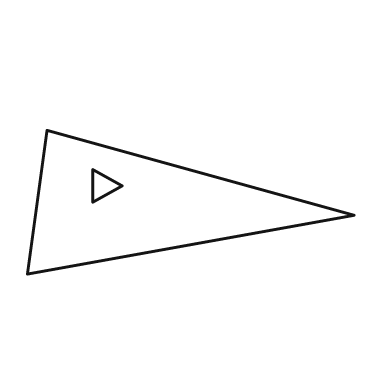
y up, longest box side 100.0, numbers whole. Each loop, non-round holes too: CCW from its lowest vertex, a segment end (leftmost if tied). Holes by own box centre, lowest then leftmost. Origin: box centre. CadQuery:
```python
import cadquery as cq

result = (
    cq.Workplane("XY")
    .moveTo(-50.0, -22.0)
    .lineTo(50.0, -4.0)
    .lineTo(-44.0, 22.0)
    .close()
    .moveTo(-30.0, 0.0)
    .lineTo(-21.0, 5.0)
    .lineTo(-30.0, 10.0)
    .close()
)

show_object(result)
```